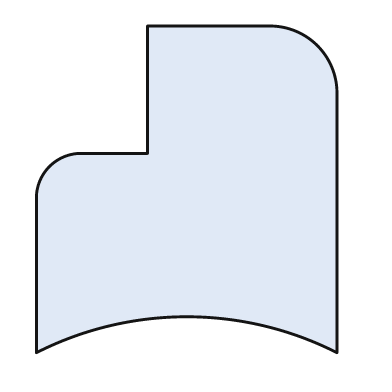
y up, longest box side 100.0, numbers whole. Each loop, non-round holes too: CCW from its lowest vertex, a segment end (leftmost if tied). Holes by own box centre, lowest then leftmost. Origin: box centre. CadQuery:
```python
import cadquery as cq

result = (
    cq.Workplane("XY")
    .moveTo(-46.0, -50.0)
    .threePointArc((0.0, -39.0), (46.0, -50.0))
    .lineTo(46.0, 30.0)
    .threePointArc((40.0, 44.0), (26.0, 50.0))
    .lineTo(-12.0, 50.0)
    .lineTo(-12.0, 11.0)
    .lineTo(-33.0, 11.0)
    .threePointArc((-42.0, 7.0), (-46.0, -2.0))
    .close()
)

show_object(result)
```